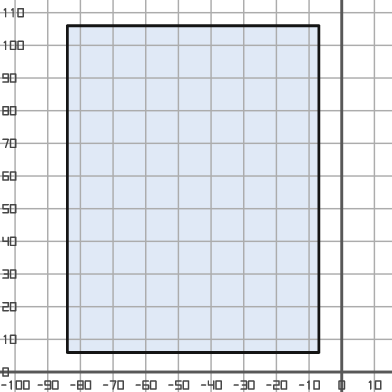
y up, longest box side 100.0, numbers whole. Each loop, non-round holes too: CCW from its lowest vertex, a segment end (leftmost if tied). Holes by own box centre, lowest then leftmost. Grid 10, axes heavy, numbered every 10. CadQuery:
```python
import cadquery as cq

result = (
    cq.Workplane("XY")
    .moveTo(-84.0, 6.0)
    .lineTo(-7.0, 6.0)
    .lineTo(-7.0, 106.0)
    .lineTo(-84.0, 106.0)
    .close()
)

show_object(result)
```